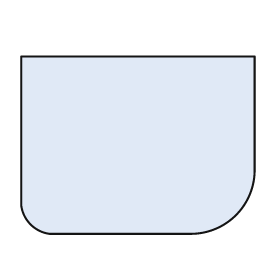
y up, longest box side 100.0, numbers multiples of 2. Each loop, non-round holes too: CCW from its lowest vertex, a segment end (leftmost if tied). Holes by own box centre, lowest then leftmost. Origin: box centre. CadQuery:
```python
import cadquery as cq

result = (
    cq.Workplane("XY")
    .moveTo(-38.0, -38.0)
    .lineTo(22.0, -38.0)
    .threePointArc((42.0, -30.0), (50.0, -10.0))
    .lineTo(50.0, 38.0)
    .lineTo(-50.0, 38.0)
    .lineTo(-50.0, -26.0)
    .threePointArc((-46.0, -34.0), (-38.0, -38.0))
    .close()
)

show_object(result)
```